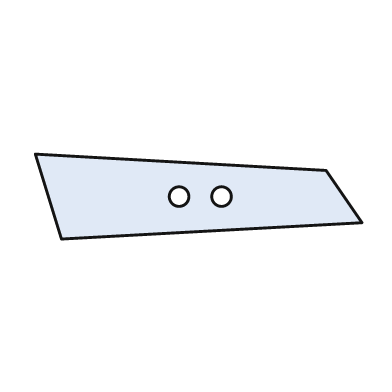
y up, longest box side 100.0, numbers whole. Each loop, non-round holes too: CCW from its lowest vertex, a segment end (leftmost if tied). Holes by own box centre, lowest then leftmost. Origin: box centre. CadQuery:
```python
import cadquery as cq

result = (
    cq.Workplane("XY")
    .moveTo(-42.0, -13.0)
    .lineTo(50.0, -8.0)
    .lineTo(39.0, 8.0)
    .lineTo(-50.0, 13.0)
    .close()
    .moveTo(-6.0, 0.0)
    .circle(3.0)
    .moveTo(7.0, 0.0)
    .circle(3.0)
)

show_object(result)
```